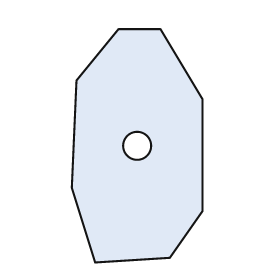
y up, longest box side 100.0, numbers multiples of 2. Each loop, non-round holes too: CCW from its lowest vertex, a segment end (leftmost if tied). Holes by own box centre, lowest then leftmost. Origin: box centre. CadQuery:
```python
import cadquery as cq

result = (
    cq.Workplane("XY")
    .moveTo(-18.0, -50.0)
    .lineTo(14.0, -48.0)
    .lineTo(28.0, -28.0)
    .lineTo(28.0, 20.0)
    .lineTo(10.0, 50.0)
    .lineTo(-8.0, 50.0)
    .lineTo(-26.0, 28.0)
    .lineTo(-28.0, -18.0)
    .close()
    .moveTo(0.0, 0.0)
    .circle(6.0)
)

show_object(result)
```